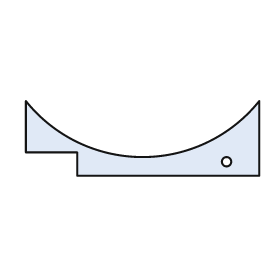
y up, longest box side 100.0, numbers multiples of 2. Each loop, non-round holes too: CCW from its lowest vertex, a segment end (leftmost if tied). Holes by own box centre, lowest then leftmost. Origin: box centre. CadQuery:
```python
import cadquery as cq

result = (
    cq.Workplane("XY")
    .moveTo(-28.0, -16.0)
    .lineTo(50.0, -16.0)
    .lineTo(50.0, 16.0)
    .threePointArc((0.0, -8.0), (-50.0, 16.0))
    .lineTo(-50.0, -6.0)
    .lineTo(-28.0, -6.0)
    .close()
    .moveTo(36.0, -10.0)
    .circle(2.0)
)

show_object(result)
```